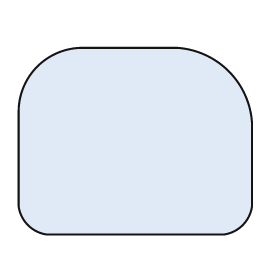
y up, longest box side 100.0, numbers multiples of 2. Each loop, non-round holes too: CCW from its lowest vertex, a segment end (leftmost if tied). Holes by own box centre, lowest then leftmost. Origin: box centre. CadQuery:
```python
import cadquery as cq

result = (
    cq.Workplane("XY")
    .moveTo(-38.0, -40.0)
    .lineTo(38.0, -40.0)
    .threePointArc((46.0, -36.0), (50.0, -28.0))
    .lineTo(50.0, 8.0)
    .threePointArc((40.0, 30.0), (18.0, 40.0))
    .lineTo(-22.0, 40.0)
    .threePointArc((-42.0, 32.0), (-50.0, 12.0))
    .lineTo(-50.0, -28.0)
    .threePointArc((-46.0, -36.0), (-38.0, -40.0))
    .close()
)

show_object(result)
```